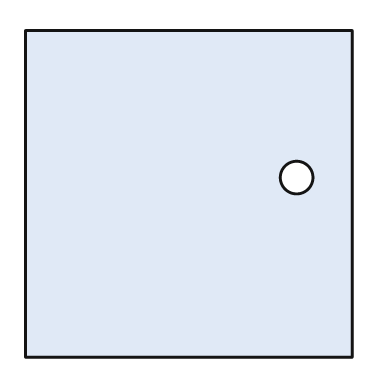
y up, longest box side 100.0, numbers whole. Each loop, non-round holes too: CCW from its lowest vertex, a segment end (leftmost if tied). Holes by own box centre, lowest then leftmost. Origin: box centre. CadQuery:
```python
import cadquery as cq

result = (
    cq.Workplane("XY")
    .moveTo(-50.0, -50.0)
    .lineTo(50.0, -50.0)
    .lineTo(50.0, 50.0)
    .lineTo(-50.0, 50.0)
    .close()
    .moveTo(33.0, 5.0)
    .circle(5.0)
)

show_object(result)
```